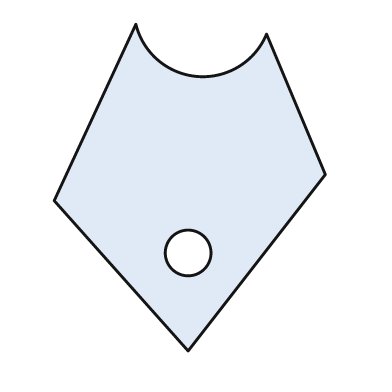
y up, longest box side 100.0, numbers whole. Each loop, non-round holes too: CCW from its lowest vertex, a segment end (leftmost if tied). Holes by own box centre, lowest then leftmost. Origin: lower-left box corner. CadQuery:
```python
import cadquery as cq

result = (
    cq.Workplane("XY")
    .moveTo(41.0, 0.0)
    .lineTo(83.0, 54.0)
    .lineTo(65.0, 97.0)
    .threePointArc((44.0, 84.0), (25.0, 100.0))
    .lineTo(0.0, 46.0)
    .close()
    .moveTo(41.0, 30.0)
    .circle(7.0)
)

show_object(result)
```